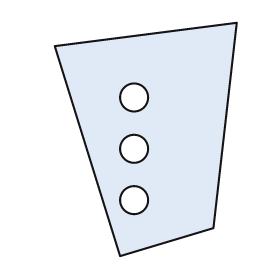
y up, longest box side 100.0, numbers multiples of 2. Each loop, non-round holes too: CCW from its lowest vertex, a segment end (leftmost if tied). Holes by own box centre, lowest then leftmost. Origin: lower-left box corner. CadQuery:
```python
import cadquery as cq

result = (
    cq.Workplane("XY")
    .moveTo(28.0, 0.0)
    .lineTo(68.0, 12.0)
    .lineTo(78.0, 100.0)
    .lineTo(0.0, 90.0)
    .close()
    .moveTo(34.0, 24.0)
    .circle(6.0)
    .moveTo(34.0, 46.0)
    .circle(6.0)
    .moveTo(34.0, 68.0)
    .circle(6.0)
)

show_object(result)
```